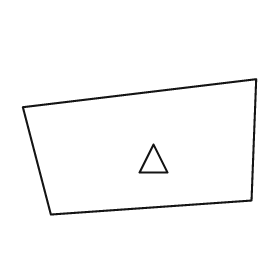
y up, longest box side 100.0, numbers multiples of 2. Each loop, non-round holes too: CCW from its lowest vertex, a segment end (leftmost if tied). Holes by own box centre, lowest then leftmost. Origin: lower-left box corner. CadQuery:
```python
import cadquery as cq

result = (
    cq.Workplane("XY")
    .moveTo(12.0, 0.0)
    .lineTo(98.0, 6.0)
    .lineTo(100.0, 58.0)
    .lineTo(0.0, 46.0)
    .close()
    .moveTo(50.0, 18.0)
    .lineTo(62.0, 18.0)
    .lineTo(56.0, 30.0)
    .close()
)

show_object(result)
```